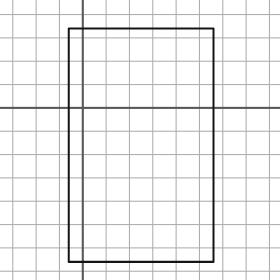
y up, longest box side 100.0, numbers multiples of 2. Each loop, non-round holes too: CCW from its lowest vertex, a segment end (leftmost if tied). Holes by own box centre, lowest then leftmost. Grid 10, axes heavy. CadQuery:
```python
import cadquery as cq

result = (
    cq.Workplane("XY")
    .moveTo(-6.0, -66.0)
    .lineTo(56.0, -66.0)
    .lineTo(56.0, 34.0)
    .lineTo(-6.0, 34.0)
    .close()
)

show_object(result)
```